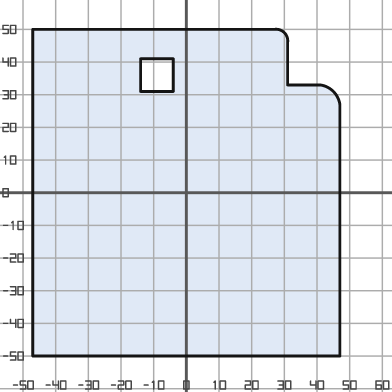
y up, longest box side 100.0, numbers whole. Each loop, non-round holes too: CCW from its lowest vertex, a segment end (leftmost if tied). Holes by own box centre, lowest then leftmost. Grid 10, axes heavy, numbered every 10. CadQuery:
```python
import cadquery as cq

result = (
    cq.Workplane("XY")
    .moveTo(-47.0, -50.0)
    .lineTo(47.0, -50.0)
    .lineTo(47.0, 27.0)
    .threePointArc((45.0, 31.0), (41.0, 33.0))
    .lineTo(31.0, 33.0)
    .lineTo(31.0, 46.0)
    .threePointArc((30.0, 49.0), (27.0, 50.0))
    .lineTo(-47.0, 50.0)
    .close()
    .moveTo(-14.0, 31.0)
    .lineTo(-4.0, 31.0)
    .lineTo(-4.0, 41.0)
    .lineTo(-14.0, 41.0)
    .close()
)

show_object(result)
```